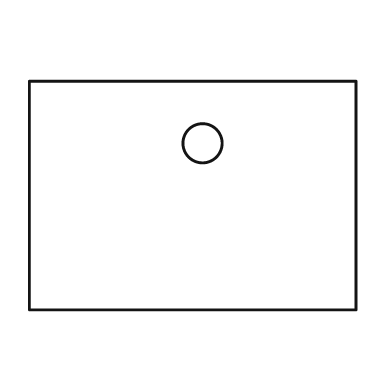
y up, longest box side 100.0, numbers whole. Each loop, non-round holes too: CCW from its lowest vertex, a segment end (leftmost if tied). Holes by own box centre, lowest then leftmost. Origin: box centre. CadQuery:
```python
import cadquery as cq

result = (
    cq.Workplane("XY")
    .moveTo(-50.0, -35.0)
    .lineTo(50.0, -35.0)
    .lineTo(50.0, 35.0)
    .lineTo(-50.0, 35.0)
    .close()
    .moveTo(3.0, 16.0)
    .circle(6.0)
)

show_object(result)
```